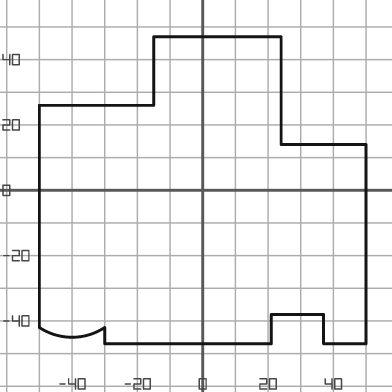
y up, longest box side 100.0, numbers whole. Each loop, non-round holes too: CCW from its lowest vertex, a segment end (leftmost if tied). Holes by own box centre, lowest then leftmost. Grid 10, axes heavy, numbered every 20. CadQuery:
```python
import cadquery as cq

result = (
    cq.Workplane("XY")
    .moveTo(-30.0, -47.0)
    .lineTo(21.0, -47.0)
    .lineTo(21.0, -38.0)
    .lineTo(37.0, -38.0)
    .lineTo(37.0, -47.0)
    .lineTo(50.0, -47.0)
    .lineTo(50.0, 14.0)
    .lineTo(24.0, 14.0)
    .lineTo(24.0, 47.0)
    .lineTo(-15.0, 47.0)
    .lineTo(-15.0, 26.0)
    .lineTo(-50.0, 26.0)
    .lineTo(-50.0, -42.0)
    .threePointArc((-40.0, -45.0), (-30.0, -42.0))
    .close()
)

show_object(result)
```